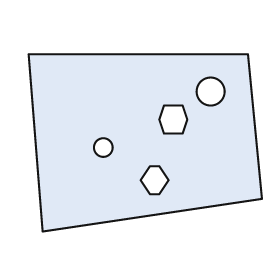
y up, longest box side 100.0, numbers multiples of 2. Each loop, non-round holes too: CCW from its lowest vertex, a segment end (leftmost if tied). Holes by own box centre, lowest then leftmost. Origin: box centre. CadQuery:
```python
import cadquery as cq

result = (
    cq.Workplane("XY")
    .moveTo(-44.0, -38.0)
    .lineTo(50.0, -24.0)
    .lineTo(44.0, 38.0)
    .lineTo(-50.0, 38.0)
    .close()
    .moveTo(2.0, -22.0)
    .lineTo(6.0, -22.0)
    .lineTo(10.0, -16.0)
    .lineTo(6.0, -10.0)
    .lineTo(2.0, -10.0)
    .lineTo(-2.0, -16.0)
    .close()
    .moveTo(-18.0, -2.0)
    .circle(4.0)
    .moveTo(8.0, 4.0)
    .lineTo(16.0, 4.0)
    .lineTo(18.0, 10.0)
    .lineTo(16.0, 16.0)
    .lineTo(8.0, 16.0)
    .lineTo(6.0, 10.0)
    .close()
    .moveTo(28.0, 22.0)
    .circle(6.0)
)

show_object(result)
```